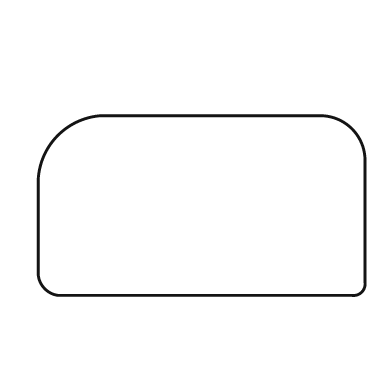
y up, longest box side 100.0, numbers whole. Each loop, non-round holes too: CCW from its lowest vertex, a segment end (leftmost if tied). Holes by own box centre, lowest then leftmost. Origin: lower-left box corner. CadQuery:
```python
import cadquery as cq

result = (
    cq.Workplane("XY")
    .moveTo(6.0, 0.0)
    .lineTo(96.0, 0.0)
    .threePointArc((99.0, 1.0), (100.0, 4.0))
    .lineTo(100.0, 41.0)
    .threePointArc((96.0, 51.0), (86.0, 55.0))
    .lineTo(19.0, 55.0)
    .threePointArc((6.0, 49.0), (0.0, 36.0))
    .lineTo(0.0, 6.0)
    .threePointArc((2.0, 2.0), (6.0, 0.0))
    .close()
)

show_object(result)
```